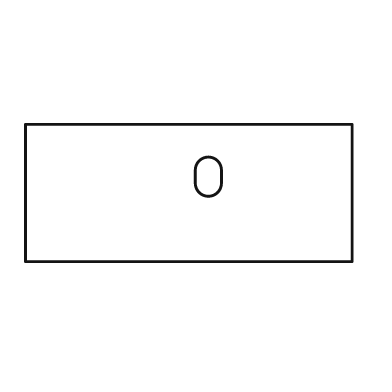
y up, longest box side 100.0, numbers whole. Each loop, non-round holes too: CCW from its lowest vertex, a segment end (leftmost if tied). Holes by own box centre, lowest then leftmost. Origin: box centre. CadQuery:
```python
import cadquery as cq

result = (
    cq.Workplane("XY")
    .moveTo(-50.0, -21.0)
    .lineTo(50.0, -21.0)
    .lineTo(50.0, 21.0)
    .lineTo(-50.0, 21.0)
    .close()
    .moveTo(2.0, 3.0)
    .threePointArc((6.0, -1.0), (10.0, 3.0))
    .lineTo(10.0, 7.0)
    .threePointArc((6.0, 11.0), (2.0, 7.0))
    .close()
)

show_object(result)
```